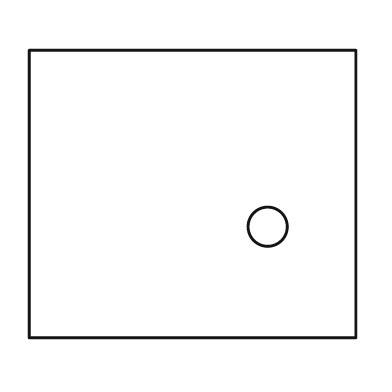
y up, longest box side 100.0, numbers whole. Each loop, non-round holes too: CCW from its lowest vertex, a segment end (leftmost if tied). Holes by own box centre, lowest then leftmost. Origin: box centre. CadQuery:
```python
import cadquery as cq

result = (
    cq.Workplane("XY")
    .moveTo(-50.0, -44.0)
    .lineTo(50.0, -44.0)
    .lineTo(50.0, 44.0)
    .lineTo(-50.0, 44.0)
    .close()
    .moveTo(23.0, -10.0)
    .circle(6.0)
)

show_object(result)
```